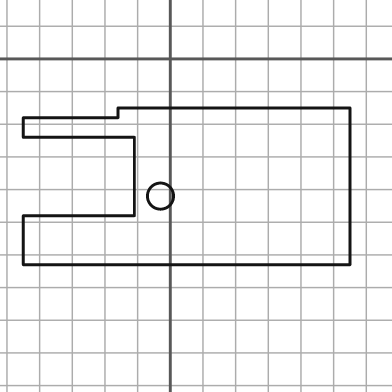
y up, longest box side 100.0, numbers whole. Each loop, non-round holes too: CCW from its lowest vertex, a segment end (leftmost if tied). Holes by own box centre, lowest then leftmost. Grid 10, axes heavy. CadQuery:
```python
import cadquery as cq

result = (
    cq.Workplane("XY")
    .moveTo(-45.0, -63.0)
    .lineTo(55.0, -63.0)
    .lineTo(55.0, -15.0)
    .lineTo(-16.0, -15.0)
    .lineTo(-16.0, -18.0)
    .lineTo(-45.0, -18.0)
    .lineTo(-45.0, -24.0)
    .lineTo(-11.0, -24.0)
    .lineTo(-11.0, -48.0)
    .lineTo(-45.0, -48.0)
    .close()
    .moveTo(-3.0, -42.0)
    .circle(4.0)
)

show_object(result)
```